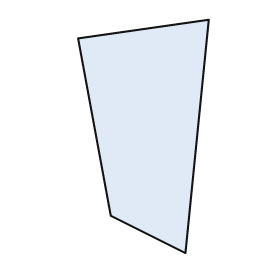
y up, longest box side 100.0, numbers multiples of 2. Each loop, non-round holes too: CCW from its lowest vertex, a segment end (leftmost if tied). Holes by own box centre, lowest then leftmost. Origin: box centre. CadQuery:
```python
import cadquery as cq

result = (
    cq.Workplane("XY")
    .moveTo(18.0, -50.0)
    .lineTo(28.0, 50.0)
    .lineTo(-28.0, 42.0)
    .lineTo(-14.0, -34.0)
    .close()
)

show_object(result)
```